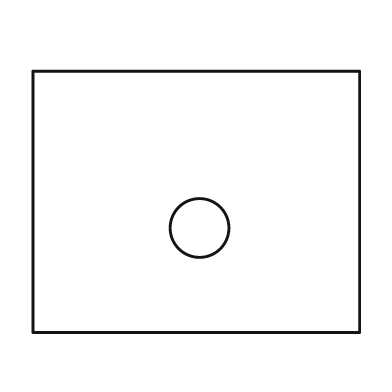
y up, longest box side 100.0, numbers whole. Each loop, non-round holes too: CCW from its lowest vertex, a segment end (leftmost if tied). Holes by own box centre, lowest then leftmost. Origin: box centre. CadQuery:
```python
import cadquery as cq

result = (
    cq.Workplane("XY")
    .moveTo(-50.0, -40.0)
    .lineTo(50.0, -40.0)
    .lineTo(50.0, 40.0)
    .lineTo(-50.0, 40.0)
    .close()
    .moveTo(1.0, -8.0)
    .circle(9.0)
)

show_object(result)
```